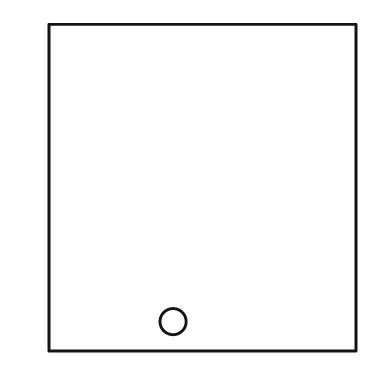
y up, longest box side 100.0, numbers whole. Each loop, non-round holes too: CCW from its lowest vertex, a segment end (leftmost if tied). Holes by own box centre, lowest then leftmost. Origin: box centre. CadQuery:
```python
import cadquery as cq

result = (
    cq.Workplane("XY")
    .moveTo(-47.0, -50.0)
    .lineTo(47.0, -50.0)
    .lineTo(47.0, 50.0)
    .lineTo(-47.0, 50.0)
    .close()
    .moveTo(-9.0, -41.0)
    .circle(4.0)
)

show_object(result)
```